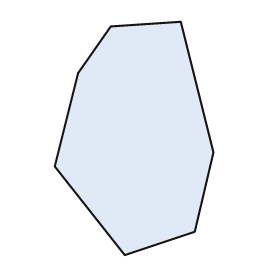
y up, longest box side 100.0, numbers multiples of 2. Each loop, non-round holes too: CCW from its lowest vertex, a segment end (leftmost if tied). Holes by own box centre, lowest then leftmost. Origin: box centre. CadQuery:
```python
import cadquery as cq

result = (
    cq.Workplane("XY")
    .moveTo(-4.0, -50.0)
    .lineTo(26.0, -40.0)
    .lineTo(34.0, -6.0)
    .lineTo(20.0, 50.0)
    .lineTo(-10.0, 48.0)
    .lineTo(-24.0, 28.0)
    .lineTo(-34.0, -12.0)
    .close()
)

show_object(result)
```